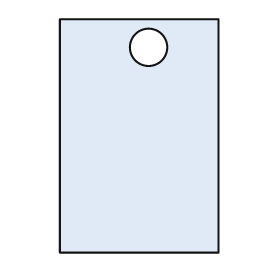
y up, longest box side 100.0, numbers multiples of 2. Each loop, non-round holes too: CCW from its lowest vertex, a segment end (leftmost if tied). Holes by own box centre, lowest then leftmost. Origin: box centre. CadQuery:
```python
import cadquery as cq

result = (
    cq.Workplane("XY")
    .moveTo(-34.0, -50.0)
    .lineTo(34.0, -50.0)
    .lineTo(34.0, 50.0)
    .lineTo(-34.0, 50.0)
    .close()
    .moveTo(4.0, 38.0)
    .circle(8.0)
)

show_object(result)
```